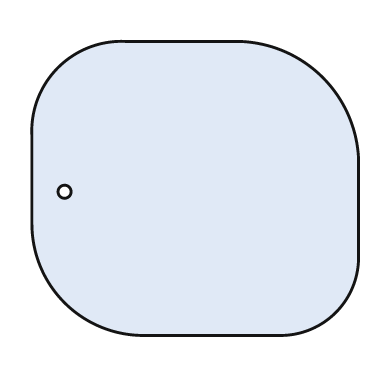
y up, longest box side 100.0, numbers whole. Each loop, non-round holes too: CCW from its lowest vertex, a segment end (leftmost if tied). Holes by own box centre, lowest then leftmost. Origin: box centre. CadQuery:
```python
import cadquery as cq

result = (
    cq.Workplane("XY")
    .moveTo(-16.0, -45.0)
    .lineTo(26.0, -45.0)
    .threePointArc((43.0, -38.0), (50.0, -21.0))
    .lineTo(50.0, 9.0)
    .threePointArc((39.0, 34.0), (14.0, 45.0))
    .lineTo(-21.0, 45.0)
    .threePointArc((-42.0, 37.0), (-50.0, 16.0))
    .lineTo(-50.0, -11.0)
    .threePointArc((-40.0, -35.0), (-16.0, -45.0))
    .close()
    .moveTo(-40.0, -1.0)
    .circle(2.0)
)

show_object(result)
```